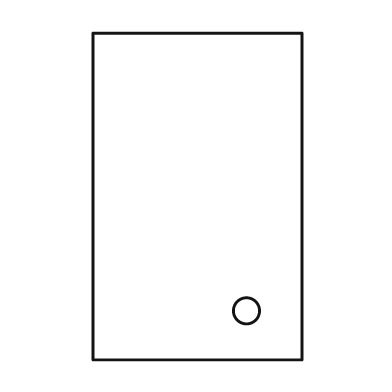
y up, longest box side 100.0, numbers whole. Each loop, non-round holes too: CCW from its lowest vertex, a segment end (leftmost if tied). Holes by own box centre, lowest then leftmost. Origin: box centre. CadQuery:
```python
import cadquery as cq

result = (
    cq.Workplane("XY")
    .moveTo(-32.0, -50.0)
    .lineTo(32.0, -50.0)
    .lineTo(32.0, 50.0)
    .lineTo(-32.0, 50.0)
    .close()
    .moveTo(15.0, -35.0)
    .circle(4.0)
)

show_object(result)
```